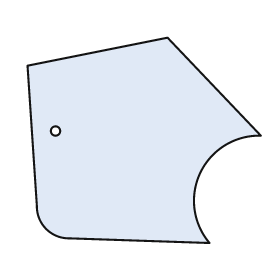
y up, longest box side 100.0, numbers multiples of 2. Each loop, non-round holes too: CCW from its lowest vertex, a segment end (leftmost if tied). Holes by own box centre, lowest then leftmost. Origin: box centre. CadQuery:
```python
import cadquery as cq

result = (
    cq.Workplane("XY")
    .moveTo(28.0, -44.0)
    .threePointArc((24.0, -14.0), (50.0, 2.0))
    .lineTo(10.0, 44.0)
    .lineTo(-50.0, 32.0)
    .lineTo(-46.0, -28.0)
    .threePointArc((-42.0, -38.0), (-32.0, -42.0))
    .close()
    .moveTo(-38.0, 4.0)
    .circle(2.0)
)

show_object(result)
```